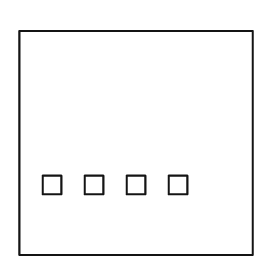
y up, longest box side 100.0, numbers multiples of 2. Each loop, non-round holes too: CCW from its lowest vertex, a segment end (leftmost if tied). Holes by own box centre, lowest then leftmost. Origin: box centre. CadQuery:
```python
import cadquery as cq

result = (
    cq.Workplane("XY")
    .moveTo(-50.0, -48.0)
    .lineTo(50.0, -48.0)
    .lineTo(50.0, 48.0)
    .lineTo(-50.0, 48.0)
    .close()
    .moveTo(-40.0, -22.0)
    .lineTo(-32.0, -22.0)
    .lineTo(-32.0, -14.0)
    .lineTo(-40.0, -14.0)
    .close()
    .moveTo(-22.0, -22.0)
    .lineTo(-14.0, -22.0)
    .lineTo(-14.0, -14.0)
    .lineTo(-22.0, -14.0)
    .close()
    .moveTo(-4.0, -22.0)
    .lineTo(4.0, -22.0)
    .lineTo(4.0, -14.0)
    .lineTo(-4.0, -14.0)
    .close()
    .moveTo(14.0, -22.0)
    .lineTo(22.0, -22.0)
    .lineTo(22.0, -14.0)
    .lineTo(14.0, -14.0)
    .close()
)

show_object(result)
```